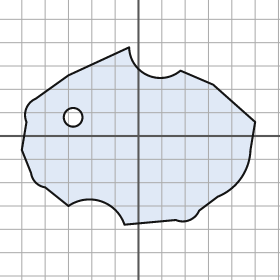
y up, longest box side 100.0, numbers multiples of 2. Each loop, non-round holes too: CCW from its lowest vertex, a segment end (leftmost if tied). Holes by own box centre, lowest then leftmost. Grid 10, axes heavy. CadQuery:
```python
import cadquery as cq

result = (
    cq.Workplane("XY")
    .moveTo(-6.0, -38.0)
    .lineTo(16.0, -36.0)
    .threePointArc((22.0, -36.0), (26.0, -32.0))
    .lineTo(34.0, -26.0)
    .threePointArc((44.0, -18.0), (48.0, -6.0))
    .lineTo(50.0, 6.0)
    .lineTo(32.0, 22.0)
    .lineTo(18.0, 28.0)
    .threePointArc((4.0, 26.0), (-4.0, 38.0))
    .lineTo(-30.0, 26.0)
    .lineTo(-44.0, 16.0)
    .threePointArc((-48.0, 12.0), (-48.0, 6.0))
    .lineTo(-50.0, -6.0)
    .lineTo(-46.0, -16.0)
    .threePointArc((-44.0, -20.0), (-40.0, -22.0))
    .lineTo(-30.0, -30.0)
    .threePointArc((-16.0, -28.0), (-6.0, -38.0))
    .close()
    .moveTo(-28.0, 8.0)
    .circle(4.0)
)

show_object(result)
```